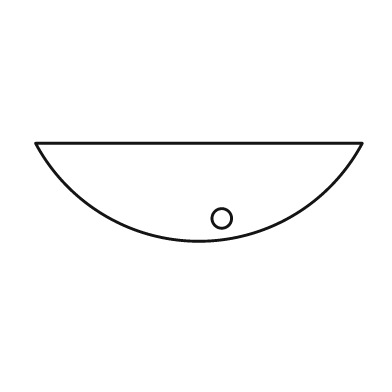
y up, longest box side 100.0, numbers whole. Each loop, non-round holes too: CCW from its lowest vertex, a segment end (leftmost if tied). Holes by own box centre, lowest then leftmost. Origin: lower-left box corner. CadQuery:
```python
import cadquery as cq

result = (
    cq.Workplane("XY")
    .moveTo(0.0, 30.0)
    .threePointArc((50.0, 0.0), (100.0, 30.0))
    .close()
    .moveTo(57.0, 7.0)
    .circle(3.0)
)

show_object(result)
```